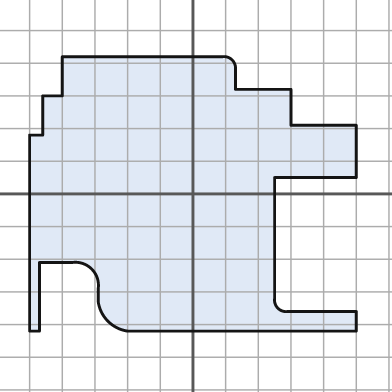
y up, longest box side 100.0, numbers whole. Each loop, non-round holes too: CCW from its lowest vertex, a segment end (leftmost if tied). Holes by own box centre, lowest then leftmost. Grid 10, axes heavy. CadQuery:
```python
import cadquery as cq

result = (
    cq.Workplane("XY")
    .moveTo(-50.0, -42.0)
    .lineTo(-47.0, -42.0)
    .lineTo(-47.0, -21.0)
    .lineTo(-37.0, -21.0)
    .threePointArc((-31.0, -23.0), (-29.0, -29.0))
    .lineTo(-29.0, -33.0)
    .threePointArc((-26.0, -39.0), (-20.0, -42.0))
    .lineTo(50.0, -42.0)
    .lineTo(50.0, -36.0)
    .lineTo(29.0, -36.0)
    .threePointArc((26.0, -35.0), (25.0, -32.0))
    .lineTo(25.0, 5.0)
    .lineTo(50.0, 5.0)
    .lineTo(50.0, 21.0)
    .lineTo(30.0, 21.0)
    .lineTo(30.0, 32.0)
    .lineTo(13.0, 32.0)
    .lineTo(13.0, 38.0)
    .threePointArc((12.0, 41.0), (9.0, 42.0))
    .lineTo(-40.0, 42.0)
    .lineTo(-40.0, 30.0)
    .lineTo(-46.0, 30.0)
    .lineTo(-46.0, 18.0)
    .lineTo(-50.0, 18.0)
    .close()
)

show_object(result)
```